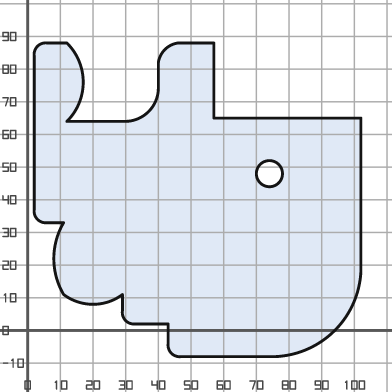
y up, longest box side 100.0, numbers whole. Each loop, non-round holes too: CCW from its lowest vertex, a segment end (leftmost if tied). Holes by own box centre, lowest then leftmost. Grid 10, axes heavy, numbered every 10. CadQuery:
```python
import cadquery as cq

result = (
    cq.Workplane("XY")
    .moveTo(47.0, -8.0)
    .lineTo(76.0, -8.0)
    .threePointArc((94.0, 0.0), (102.0, 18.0))
    .lineTo(102.0, 65.0)
    .lineTo(57.0, 65.0)
    .lineTo(57.0, 88.0)
    .lineTo(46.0, 88.0)
    .threePointArc((42.0, 86.0), (40.0, 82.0))
    .lineTo(40.0, 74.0)
    .threePointArc((37.0, 67.0), (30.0, 64.0))
    .lineTo(12.0, 64.0)
    .threePointArc((17.0, 76.0), (12.0, 88.0))
    .lineTo(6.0, 88.0)
    .threePointArc((3.0, 87.0), (2.0, 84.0))
    .lineTo(2.0, 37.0)
    .threePointArc((3.0, 34.0), (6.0, 33.0))
    .lineTo(11.0, 33.0)
    .threePointArc((8.0, 22.0), (11.0, 11.0))
    .threePointArc((20.0, 8.0), (29.0, 11.0))
    .lineTo(29.0, 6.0)
    .threePointArc((30.0, 3.0), (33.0, 2.0))
    .lineTo(43.0, 2.0)
    .lineTo(43.0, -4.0)
    .threePointArc((44.0, -7.0), (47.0, -8.0))
    .close()
    .moveTo(74.0, 48.0)
    .circle(4.0)
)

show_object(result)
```